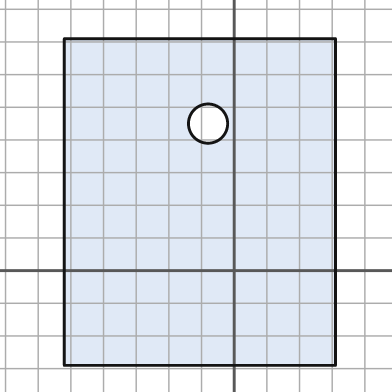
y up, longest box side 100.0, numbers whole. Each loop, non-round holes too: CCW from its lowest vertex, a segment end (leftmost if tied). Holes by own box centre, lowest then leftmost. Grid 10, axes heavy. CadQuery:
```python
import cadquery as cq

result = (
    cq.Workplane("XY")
    .moveTo(-52.0, -29.0)
    .lineTo(31.0, -29.0)
    .lineTo(31.0, 71.0)
    .lineTo(-52.0, 71.0)
    .close()
    .moveTo(-8.0, 45.0)
    .circle(6.0)
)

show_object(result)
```